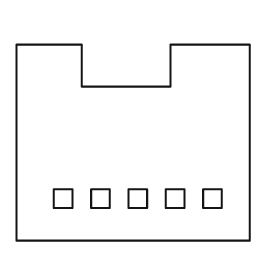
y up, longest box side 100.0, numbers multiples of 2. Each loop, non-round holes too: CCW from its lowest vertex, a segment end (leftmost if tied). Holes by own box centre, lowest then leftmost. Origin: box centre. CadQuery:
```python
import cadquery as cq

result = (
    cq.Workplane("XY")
    .moveTo(-50.0, -42.0)
    .lineTo(50.0, -42.0)
    .lineTo(50.0, 42.0)
    .lineTo(16.0, 42.0)
    .lineTo(16.0, 24.0)
    .lineTo(-22.0, 24.0)
    .lineTo(-22.0, 42.0)
    .lineTo(-50.0, 42.0)
    .close()
    .moveTo(-34.0, -28.0)
    .lineTo(-26.0, -28.0)
    .lineTo(-26.0, -20.0)
    .lineTo(-34.0, -20.0)
    .close()
    .moveTo(-18.0, -28.0)
    .lineTo(-10.0, -28.0)
    .lineTo(-10.0, -20.0)
    .lineTo(-18.0, -20.0)
    .close()
    .moveTo(-2.0, -28.0)
    .lineTo(6.0, -28.0)
    .lineTo(6.0, -20.0)
    .lineTo(-2.0, -20.0)
    .close()
    .moveTo(14.0, -28.0)
    .lineTo(22.0, -28.0)
    .lineTo(22.0, -20.0)
    .lineTo(14.0, -20.0)
    .close()
    .moveTo(30.0, -28.0)
    .lineTo(38.0, -28.0)
    .lineTo(38.0, -20.0)
    .lineTo(30.0, -20.0)
    .close()
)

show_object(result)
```